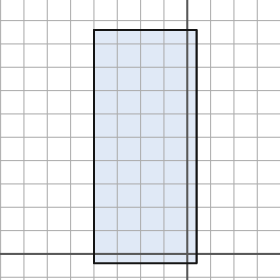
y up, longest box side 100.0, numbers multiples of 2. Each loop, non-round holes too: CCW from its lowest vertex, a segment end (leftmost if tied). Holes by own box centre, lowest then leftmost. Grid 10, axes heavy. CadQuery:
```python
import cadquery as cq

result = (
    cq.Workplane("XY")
    .moveTo(-40.0, -4.0)
    .lineTo(4.0, -4.0)
    .lineTo(4.0, 96.0)
    .lineTo(-40.0, 96.0)
    .close()
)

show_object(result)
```